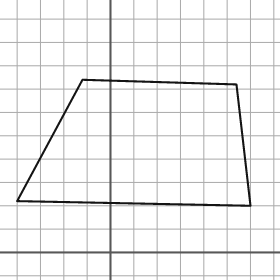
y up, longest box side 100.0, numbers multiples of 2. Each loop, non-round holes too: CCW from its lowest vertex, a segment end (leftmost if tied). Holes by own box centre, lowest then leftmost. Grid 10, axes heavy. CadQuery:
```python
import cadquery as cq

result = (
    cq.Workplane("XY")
    .moveTo(60.0, 20.0)
    .lineTo(54.0, 72.0)
    .lineTo(-12.0, 74.0)
    .lineTo(-40.0, 22.0)
    .close()
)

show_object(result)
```